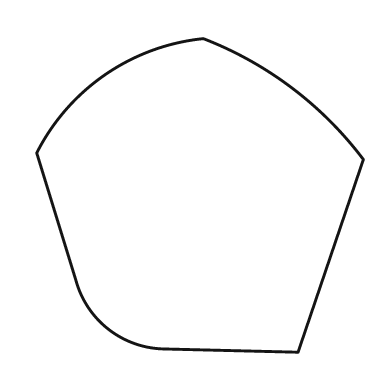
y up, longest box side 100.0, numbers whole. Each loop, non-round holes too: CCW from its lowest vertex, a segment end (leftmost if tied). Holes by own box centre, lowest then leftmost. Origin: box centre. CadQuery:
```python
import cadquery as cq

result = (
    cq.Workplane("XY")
    .moveTo(30.0, -48.0)
    .lineTo(50.0, 11.0)
    .threePointArc((28.0, 33.0), (1.0, 48.0))
    .threePointArc((-29.0, 37.0), (-50.0, 13.0))
    .lineTo(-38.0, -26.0)
    .threePointArc((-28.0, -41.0), (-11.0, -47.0))
    .close()
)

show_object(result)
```